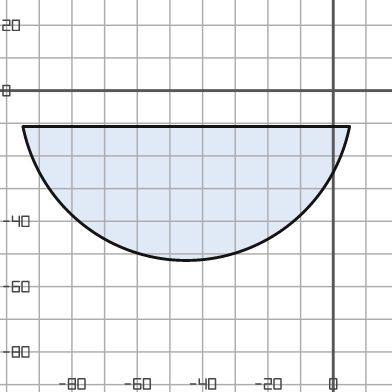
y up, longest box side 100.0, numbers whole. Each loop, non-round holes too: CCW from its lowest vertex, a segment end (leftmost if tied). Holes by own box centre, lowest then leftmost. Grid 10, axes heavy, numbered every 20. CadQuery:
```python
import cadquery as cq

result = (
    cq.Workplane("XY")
    .moveTo(-95.0, -11.0)
    .threePointArc((-45.0, -52.0), (5.0, -11.0))
    .close()
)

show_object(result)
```